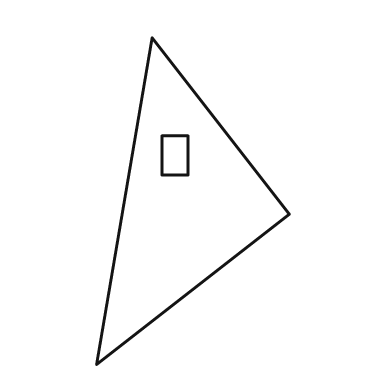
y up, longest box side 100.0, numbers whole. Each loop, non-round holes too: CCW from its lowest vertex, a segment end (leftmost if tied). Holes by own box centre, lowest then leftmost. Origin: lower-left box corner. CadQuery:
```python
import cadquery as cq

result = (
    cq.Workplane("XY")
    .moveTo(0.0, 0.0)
    .lineTo(59.0, 46.0)
    .lineTo(17.0, 100.0)
    .close()
    .moveTo(20.0, 58.0)
    .lineTo(28.0, 58.0)
    .lineTo(28.0, 70.0)
    .lineTo(20.0, 70.0)
    .close()
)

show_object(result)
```